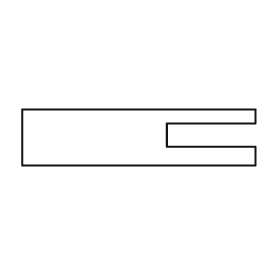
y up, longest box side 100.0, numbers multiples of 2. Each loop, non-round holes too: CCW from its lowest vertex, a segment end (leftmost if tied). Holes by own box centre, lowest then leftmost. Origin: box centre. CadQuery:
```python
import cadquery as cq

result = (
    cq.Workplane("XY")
    .moveTo(-50.0, -12.0)
    .lineTo(50.0, -12.0)
    .lineTo(50.0, -4.0)
    .lineTo(12.0, -4.0)
    .lineTo(12.0, 6.0)
    .lineTo(50.0, 6.0)
    .lineTo(50.0, 12.0)
    .lineTo(-50.0, 12.0)
    .close()
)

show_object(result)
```